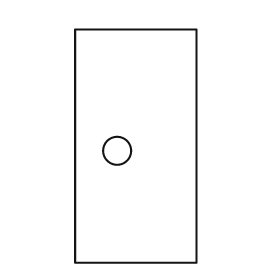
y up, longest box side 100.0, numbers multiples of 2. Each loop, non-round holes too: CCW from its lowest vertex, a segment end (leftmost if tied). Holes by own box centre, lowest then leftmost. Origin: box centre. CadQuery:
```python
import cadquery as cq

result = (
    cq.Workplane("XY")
    .moveTo(-26.0, -50.0)
    .lineTo(26.0, -50.0)
    .lineTo(26.0, 50.0)
    .lineTo(-26.0, 50.0)
    .close()
    .moveTo(-8.0, -2.0)
    .circle(6.0)
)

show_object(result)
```